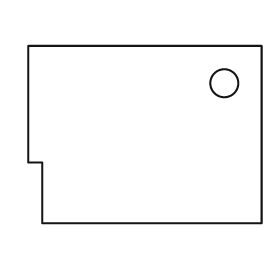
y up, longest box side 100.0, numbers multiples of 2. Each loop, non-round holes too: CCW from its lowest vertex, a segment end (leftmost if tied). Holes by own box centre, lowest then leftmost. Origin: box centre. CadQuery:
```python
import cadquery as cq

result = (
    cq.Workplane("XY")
    .moveTo(-44.0, -38.0)
    .lineTo(50.0, -38.0)
    .lineTo(50.0, 38.0)
    .lineTo(-50.0, 38.0)
    .lineTo(-50.0, -12.0)
    .lineTo(-44.0, -12.0)
    .close()
    .moveTo(34.0, 22.0)
    .circle(6.0)
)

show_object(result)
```